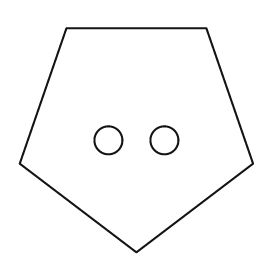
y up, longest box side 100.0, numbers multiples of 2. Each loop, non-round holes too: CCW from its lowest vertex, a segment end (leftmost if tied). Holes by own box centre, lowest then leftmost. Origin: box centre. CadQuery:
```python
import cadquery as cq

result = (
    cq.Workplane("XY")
    .moveTo(0.0, -48.0)
    .lineTo(50.0, -10.0)
    .lineTo(30.0, 48.0)
    .lineTo(-30.0, 48.0)
    .lineTo(-50.0, -10.0)
    .close()
    .moveTo(-12.0, 0.0)
    .circle(6.0)
    .moveTo(12.0, 0.0)
    .circle(6.0)
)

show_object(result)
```